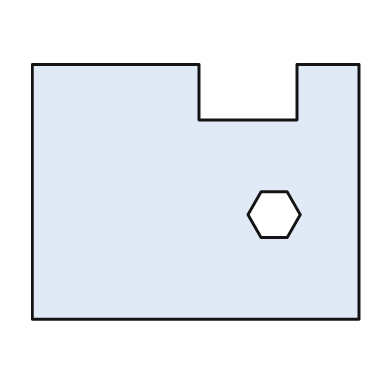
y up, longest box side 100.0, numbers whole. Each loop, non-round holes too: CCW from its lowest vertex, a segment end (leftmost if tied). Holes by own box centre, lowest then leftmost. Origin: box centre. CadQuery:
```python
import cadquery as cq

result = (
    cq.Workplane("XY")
    .moveTo(-50.0, -39.0)
    .lineTo(50.0, -39.0)
    .lineTo(50.0, 39.0)
    .lineTo(31.0, 39.0)
    .lineTo(31.0, 22.0)
    .lineTo(1.0, 22.0)
    .lineTo(1.0, 39.0)
    .lineTo(-50.0, 39.0)
    .close()
    .moveTo(20.0, -14.0)
    .lineTo(28.0, -14.0)
    .lineTo(32.0, -7.0)
    .lineTo(28.0, 0.0)
    .lineTo(20.0, 0.0)
    .lineTo(16.0, -7.0)
    .close()
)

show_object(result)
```